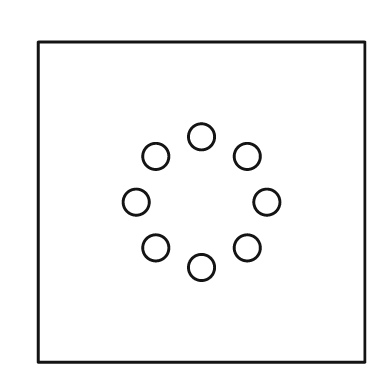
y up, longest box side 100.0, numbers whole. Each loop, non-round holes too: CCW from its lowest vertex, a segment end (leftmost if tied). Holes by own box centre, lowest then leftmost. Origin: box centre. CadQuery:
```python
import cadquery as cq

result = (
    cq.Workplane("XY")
    .moveTo(-50.0, -49.0)
    .lineTo(50.0, -49.0)
    .lineTo(50.0, 49.0)
    .lineTo(-50.0, 49.0)
    .close()
    .moveTo(0.0, -20.0)
    .circle(4.0)
    .moveTo(-14.0, -14.0)
    .circle(4.0)
    .moveTo(14.0, -14.0)
    .circle(4.0)
    .moveTo(-20.0, 0.0)
    .circle(4.0)
    .moveTo(20.0, 0.0)
    .circle(4.0)
    .moveTo(-14.0, 14.0)
    .circle(4.0)
    .moveTo(14.0, 14.0)
    .circle(4.0)
    .moveTo(0.0, 20.0)
    .circle(4.0)
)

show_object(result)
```